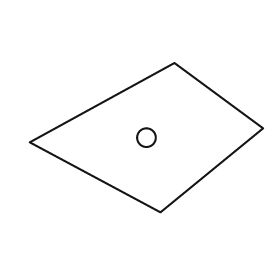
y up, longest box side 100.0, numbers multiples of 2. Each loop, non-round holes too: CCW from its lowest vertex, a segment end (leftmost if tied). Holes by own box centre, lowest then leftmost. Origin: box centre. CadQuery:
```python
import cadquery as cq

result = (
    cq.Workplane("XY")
    .moveTo(6.0, -32.0)
    .lineTo(50.0, 4.0)
    .lineTo(12.0, 32.0)
    .lineTo(-50.0, -2.0)
    .close()
    .moveTo(0.0, 0.0)
    .circle(4.0)
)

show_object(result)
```